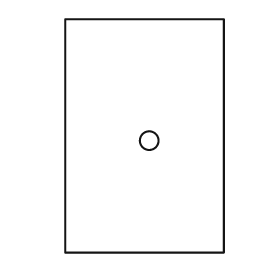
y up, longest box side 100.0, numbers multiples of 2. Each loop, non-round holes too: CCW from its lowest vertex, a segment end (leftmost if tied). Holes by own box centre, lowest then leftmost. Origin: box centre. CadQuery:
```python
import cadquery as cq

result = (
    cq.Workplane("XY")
    .moveTo(-34.0, -50.0)
    .lineTo(34.0, -50.0)
    .lineTo(34.0, 50.0)
    .lineTo(-34.0, 50.0)
    .close()
    .moveTo(2.0, -2.0)
    .circle(4.0)
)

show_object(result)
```